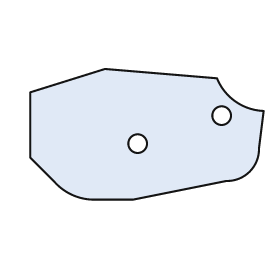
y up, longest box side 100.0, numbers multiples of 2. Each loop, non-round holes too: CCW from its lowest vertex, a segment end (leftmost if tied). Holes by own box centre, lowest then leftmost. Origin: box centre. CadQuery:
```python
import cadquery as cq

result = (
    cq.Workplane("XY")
    .moveTo(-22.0, -28.0)
    .lineTo(-6.0, -28.0)
    .lineTo(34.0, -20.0)
    .threePointArc((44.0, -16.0), (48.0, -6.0))
    .lineTo(50.0, 10.0)
    .threePointArc((38.0, 14.0), (30.0, 24.0))
    .lineTo(-18.0, 28.0)
    .lineTo(-50.0, 18.0)
    .lineTo(-50.0, -10.0)
    .lineTo(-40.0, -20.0)
    .threePointArc((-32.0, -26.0), (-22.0, -28.0))
    .close()
    .moveTo(-4.0, -4.0)
    .circle(4.0)
    .moveTo(32.0, 8.0)
    .circle(4.0)
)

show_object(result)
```